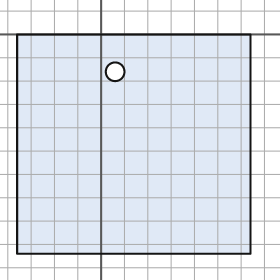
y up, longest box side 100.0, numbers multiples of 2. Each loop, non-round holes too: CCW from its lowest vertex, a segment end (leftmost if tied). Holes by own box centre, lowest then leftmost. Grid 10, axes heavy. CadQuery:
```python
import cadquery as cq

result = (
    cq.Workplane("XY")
    .moveTo(-36.0, -94.0)
    .lineTo(64.0, -94.0)
    .lineTo(64.0, 0.0)
    .lineTo(-36.0, 0.0)
    .close()
    .moveTo(6.0, -16.0)
    .circle(4.0)
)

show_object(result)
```